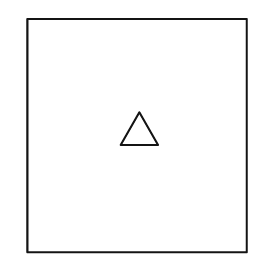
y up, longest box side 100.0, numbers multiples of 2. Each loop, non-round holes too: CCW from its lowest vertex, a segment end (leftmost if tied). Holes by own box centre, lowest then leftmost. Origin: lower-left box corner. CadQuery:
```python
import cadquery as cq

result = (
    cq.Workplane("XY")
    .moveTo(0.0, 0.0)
    .lineTo(94.0, 0.0)
    .lineTo(94.0, 100.0)
    .lineTo(0.0, 100.0)
    .close()
    .moveTo(40.0, 46.0)
    .lineTo(56.0, 46.0)
    .lineTo(48.0, 60.0)
    .close()
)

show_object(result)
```